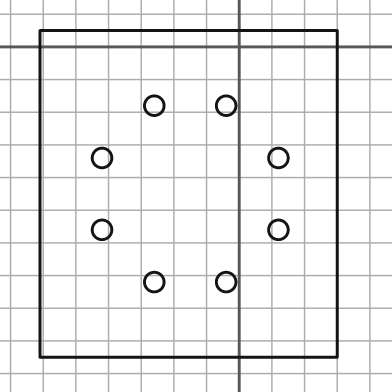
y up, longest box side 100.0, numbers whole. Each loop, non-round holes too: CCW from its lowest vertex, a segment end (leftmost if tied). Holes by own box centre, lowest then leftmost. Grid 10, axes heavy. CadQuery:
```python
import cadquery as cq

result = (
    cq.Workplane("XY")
    .moveTo(-61.0, -95.0)
    .lineTo(30.0, -95.0)
    .lineTo(30.0, 5.0)
    .lineTo(-61.0, 5.0)
    .close()
    .moveTo(-26.0, -72.0)
    .circle(3.0)
    .moveTo(-4.0, -72.0)
    .circle(3.0)
    .moveTo(-42.0, -56.0)
    .circle(3.0)
    .moveTo(12.0, -56.0)
    .circle(3.0)
    .moveTo(-42.0, -34.0)
    .circle(3.0)
    .moveTo(12.0, -34.0)
    .circle(3.0)
    .moveTo(-26.0, -18.0)
    .circle(3.0)
    .moveTo(-4.0, -18.0)
    .circle(3.0)
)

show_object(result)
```